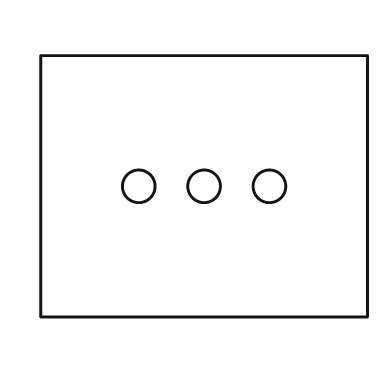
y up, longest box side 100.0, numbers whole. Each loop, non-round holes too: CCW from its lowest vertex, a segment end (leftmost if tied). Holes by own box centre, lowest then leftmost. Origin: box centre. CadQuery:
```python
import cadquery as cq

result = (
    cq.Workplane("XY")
    .moveTo(-50.0, -40.0)
    .lineTo(50.0, -40.0)
    .lineTo(50.0, 40.0)
    .lineTo(-50.0, 40.0)
    .close()
    .moveTo(-20.0, 0.0)
    .circle(5.0)
    .moveTo(0.0, 0.0)
    .circle(5.0)
    .moveTo(20.0, 0.0)
    .circle(5.0)
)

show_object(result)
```